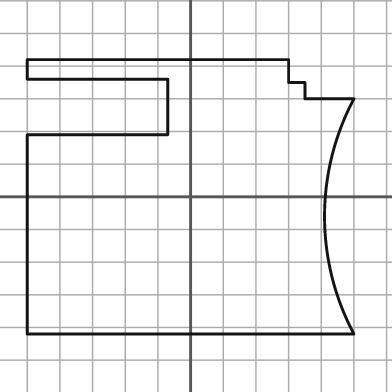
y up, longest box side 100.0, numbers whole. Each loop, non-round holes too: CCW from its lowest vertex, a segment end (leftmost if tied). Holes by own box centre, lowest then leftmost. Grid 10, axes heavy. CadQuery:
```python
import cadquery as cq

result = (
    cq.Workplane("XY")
    .moveTo(-50.0, -42.0)
    .lineTo(50.0, -42.0)
    .threePointArc((41.0, -6.0), (50.0, 30.0))
    .lineTo(35.0, 30.0)
    .lineTo(35.0, 35.0)
    .lineTo(30.0, 35.0)
    .lineTo(30.0, 42.0)
    .lineTo(-50.0, 42.0)
    .lineTo(-50.0, 36.0)
    .lineTo(-7.0, 36.0)
    .lineTo(-7.0, 19.0)
    .lineTo(-50.0, 19.0)
    .close()
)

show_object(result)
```